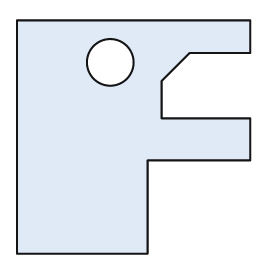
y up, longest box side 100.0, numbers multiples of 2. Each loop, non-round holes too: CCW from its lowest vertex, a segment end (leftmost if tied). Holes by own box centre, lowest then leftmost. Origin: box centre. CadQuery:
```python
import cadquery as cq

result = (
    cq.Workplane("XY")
    .moveTo(-50.0, -50.0)
    .lineTo(6.0, -50.0)
    .lineTo(6.0, -10.0)
    .lineTo(50.0, -10.0)
    .lineTo(50.0, 8.0)
    .lineTo(12.0, 8.0)
    .lineTo(12.0, 24.0)
    .lineTo(24.0, 36.0)
    .lineTo(50.0, 36.0)
    .lineTo(50.0, 50.0)
    .lineTo(-50.0, 50.0)
    .close()
    .moveTo(-10.0, 32.0)
    .circle(10.0)
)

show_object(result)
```